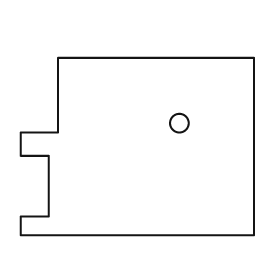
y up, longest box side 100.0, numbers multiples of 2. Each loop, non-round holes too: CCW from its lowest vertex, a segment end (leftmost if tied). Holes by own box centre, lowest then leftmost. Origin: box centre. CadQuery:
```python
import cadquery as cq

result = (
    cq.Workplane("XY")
    .moveTo(-50.0, -38.0)
    .lineTo(50.0, -38.0)
    .lineTo(50.0, 38.0)
    .lineTo(-34.0, 38.0)
    .lineTo(-34.0, 6.0)
    .lineTo(-50.0, 6.0)
    .lineTo(-50.0, -4.0)
    .lineTo(-38.0, -4.0)
    .lineTo(-38.0, -30.0)
    .lineTo(-50.0, -30.0)
    .close()
    .moveTo(18.0, 10.0)
    .circle(4.0)
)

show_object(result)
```